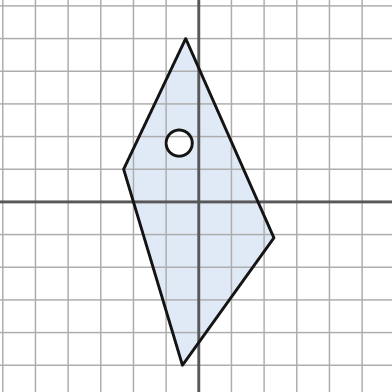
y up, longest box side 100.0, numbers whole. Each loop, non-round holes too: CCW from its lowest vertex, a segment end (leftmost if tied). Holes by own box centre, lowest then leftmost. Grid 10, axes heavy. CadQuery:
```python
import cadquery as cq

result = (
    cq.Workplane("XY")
    .moveTo(-5.0, -50.0)
    .lineTo(23.0, -11.0)
    .lineTo(-4.0, 50.0)
    .lineTo(-23.0, 10.0)
    .close()
    .moveTo(-6.0, 18.0)
    .circle(4.0)
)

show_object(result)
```